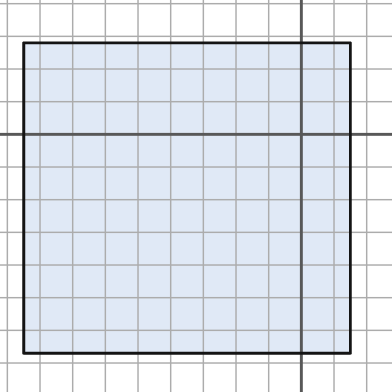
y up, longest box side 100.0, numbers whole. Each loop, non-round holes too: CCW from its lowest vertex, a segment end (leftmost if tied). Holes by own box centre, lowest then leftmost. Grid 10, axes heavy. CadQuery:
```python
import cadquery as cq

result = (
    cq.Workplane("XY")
    .moveTo(-85.0, -67.0)
    .lineTo(15.0, -67.0)
    .lineTo(15.0, 28.0)
    .lineTo(-85.0, 28.0)
    .close()
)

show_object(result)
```